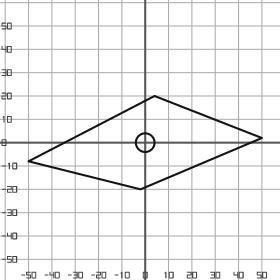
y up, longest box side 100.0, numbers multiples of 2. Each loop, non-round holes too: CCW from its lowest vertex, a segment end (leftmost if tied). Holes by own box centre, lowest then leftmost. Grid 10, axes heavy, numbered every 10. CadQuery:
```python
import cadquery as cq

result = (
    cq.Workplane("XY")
    .moveTo(-2.0, -20.0)
    .lineTo(50.0, 2.0)
    .lineTo(4.0, 20.0)
    .lineTo(-50.0, -8.0)
    .close()
    .moveTo(0.0, 0.0)
    .circle(4.0)
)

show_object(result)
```